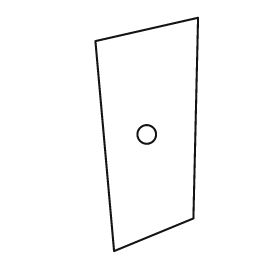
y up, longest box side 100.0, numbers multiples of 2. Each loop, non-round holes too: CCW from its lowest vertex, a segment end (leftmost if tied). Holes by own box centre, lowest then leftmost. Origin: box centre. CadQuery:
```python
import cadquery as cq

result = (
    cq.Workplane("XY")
    .moveTo(-14.0, -50.0)
    .lineTo(20.0, -36.0)
    .lineTo(22.0, 50.0)
    .lineTo(-22.0, 40.0)
    .close()
    .moveTo(0.0, 0.0)
    .circle(4.0)
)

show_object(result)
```